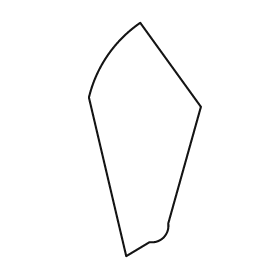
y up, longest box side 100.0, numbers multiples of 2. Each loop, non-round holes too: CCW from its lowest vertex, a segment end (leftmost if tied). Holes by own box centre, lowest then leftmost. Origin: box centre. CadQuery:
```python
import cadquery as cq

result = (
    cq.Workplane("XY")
    .moveTo(-8.0, -50.0)
    .lineTo(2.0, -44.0)
    .threePointArc((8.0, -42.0), (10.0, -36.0))
    .lineTo(24.0, 14.0)
    .lineTo(-2.0, 50.0)
    .threePointArc((-16.0, 36.0), (-24.0, 18.0))
    .close()
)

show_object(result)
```